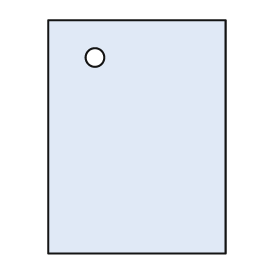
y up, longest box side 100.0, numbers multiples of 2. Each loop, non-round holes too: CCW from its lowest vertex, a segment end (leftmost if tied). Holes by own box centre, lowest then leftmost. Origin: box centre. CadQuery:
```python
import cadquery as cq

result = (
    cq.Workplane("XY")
    .moveTo(-38.0, -50.0)
    .lineTo(38.0, -50.0)
    .lineTo(38.0, 50.0)
    .lineTo(-38.0, 50.0)
    .close()
    .moveTo(-18.0, 34.0)
    .circle(4.0)
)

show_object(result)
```